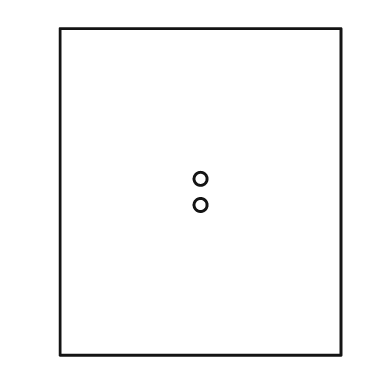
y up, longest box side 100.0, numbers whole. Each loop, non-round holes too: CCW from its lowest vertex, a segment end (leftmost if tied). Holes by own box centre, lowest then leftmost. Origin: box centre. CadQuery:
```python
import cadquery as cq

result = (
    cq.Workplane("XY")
    .moveTo(-43.0, -50.0)
    .lineTo(43.0, -50.0)
    .lineTo(43.0, 50.0)
    .lineTo(-43.0, 50.0)
    .close()
    .moveTo(0.0, -4.0)
    .circle(2.0)
    .moveTo(0.0, 4.0)
    .circle(2.0)
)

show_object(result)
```